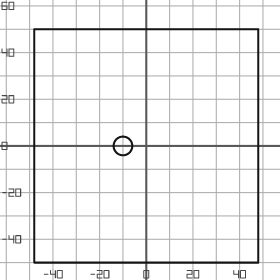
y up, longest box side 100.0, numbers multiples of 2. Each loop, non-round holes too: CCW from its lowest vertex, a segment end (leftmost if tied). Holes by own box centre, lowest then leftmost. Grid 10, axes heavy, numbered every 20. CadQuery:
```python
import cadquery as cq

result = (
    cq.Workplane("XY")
    .moveTo(-48.0, -50.0)
    .lineTo(48.0, -50.0)
    .lineTo(48.0, 50.0)
    .lineTo(-48.0, 50.0)
    .close()
    .moveTo(-10.0, 0.0)
    .circle(4.0)
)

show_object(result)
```